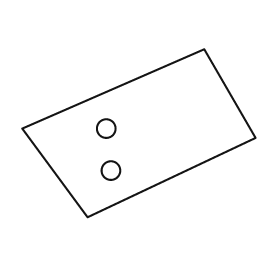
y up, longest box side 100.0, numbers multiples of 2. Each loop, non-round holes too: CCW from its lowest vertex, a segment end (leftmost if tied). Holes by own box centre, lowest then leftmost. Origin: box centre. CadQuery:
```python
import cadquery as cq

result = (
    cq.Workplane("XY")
    .moveTo(-22.0, -36.0)
    .lineTo(50.0, -2.0)
    .lineTo(28.0, 36.0)
    .lineTo(-50.0, 2.0)
    .close()
    .moveTo(-12.0, -16.0)
    .circle(4.0)
    .moveTo(-14.0, 2.0)
    .circle(4.0)
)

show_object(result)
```